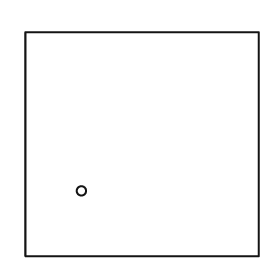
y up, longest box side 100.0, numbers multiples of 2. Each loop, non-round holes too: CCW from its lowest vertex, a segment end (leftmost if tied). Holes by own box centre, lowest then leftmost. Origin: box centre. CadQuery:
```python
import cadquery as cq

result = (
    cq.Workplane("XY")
    .moveTo(-50.0, -48.0)
    .lineTo(50.0, -48.0)
    .lineTo(50.0, 48.0)
    .lineTo(-50.0, 48.0)
    .close()
    .moveTo(-26.0, -20.0)
    .circle(2.0)
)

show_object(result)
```